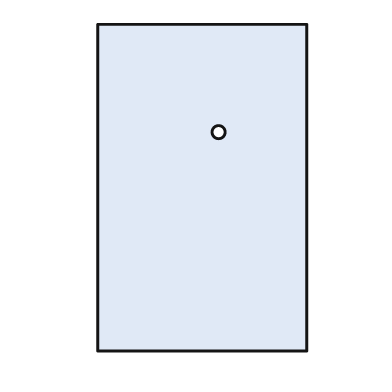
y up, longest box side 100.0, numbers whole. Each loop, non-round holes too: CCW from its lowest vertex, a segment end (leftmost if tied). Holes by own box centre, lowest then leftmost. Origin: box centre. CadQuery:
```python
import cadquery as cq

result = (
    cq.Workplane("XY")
    .moveTo(-32.0, -50.0)
    .lineTo(32.0, -50.0)
    .lineTo(32.0, 50.0)
    .lineTo(-32.0, 50.0)
    .close()
    .moveTo(5.0, 17.0)
    .circle(2.0)
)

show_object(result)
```